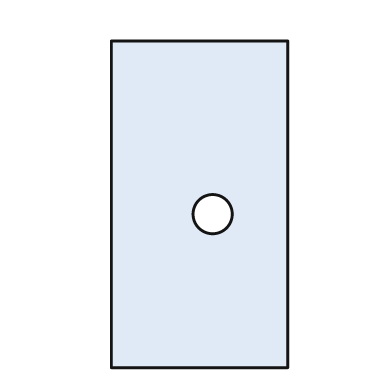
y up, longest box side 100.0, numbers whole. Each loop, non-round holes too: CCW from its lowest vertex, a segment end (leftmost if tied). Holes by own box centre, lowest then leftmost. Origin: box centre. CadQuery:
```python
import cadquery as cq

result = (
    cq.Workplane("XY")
    .moveTo(-27.0, -50.0)
    .lineTo(27.0, -50.0)
    .lineTo(27.0, 50.0)
    .lineTo(-27.0, 50.0)
    .close()
    .moveTo(4.0, -3.0)
    .circle(6.0)
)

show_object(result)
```